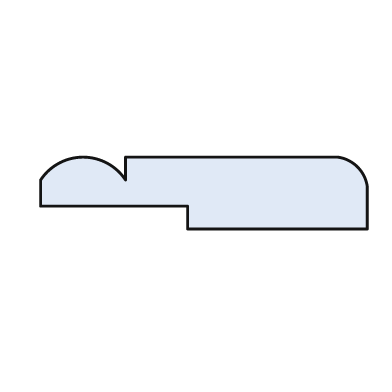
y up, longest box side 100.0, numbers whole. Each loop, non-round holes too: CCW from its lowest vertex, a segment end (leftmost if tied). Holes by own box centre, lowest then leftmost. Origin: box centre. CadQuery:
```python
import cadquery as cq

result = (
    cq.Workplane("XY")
    .moveTo(-5.0, -11.0)
    .lineTo(50.0, -11.0)
    .lineTo(50.0, 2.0)
    .threePointArc((47.0, 8.0), (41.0, 11.0))
    .lineTo(-24.0, 11.0)
    .lineTo(-24.0, 4.0)
    .threePointArc((-37.0, 11.0), (-50.0, 4.0))
    .lineTo(-50.0, -4.0)
    .lineTo(-5.0, -4.0)
    .close()
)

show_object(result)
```